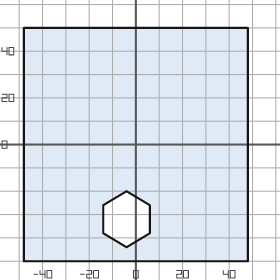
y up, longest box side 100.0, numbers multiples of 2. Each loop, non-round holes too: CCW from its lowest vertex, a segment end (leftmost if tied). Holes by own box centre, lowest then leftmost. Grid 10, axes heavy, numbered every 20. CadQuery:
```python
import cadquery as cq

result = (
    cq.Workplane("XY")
    .moveTo(-48.0, -50.0)
    .lineTo(48.0, -50.0)
    .lineTo(48.0, 50.0)
    .lineTo(-48.0, 50.0)
    .close()
    .moveTo(-4.0, -44.0)
    .lineTo(6.0, -38.0)
    .lineTo(6.0, -26.0)
    .lineTo(-4.0, -20.0)
    .lineTo(-14.0, -26.0)
    .lineTo(-14.0, -38.0)
    .close()
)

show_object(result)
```